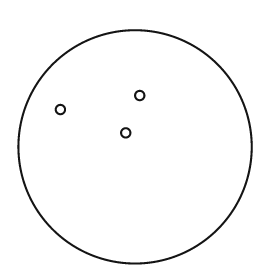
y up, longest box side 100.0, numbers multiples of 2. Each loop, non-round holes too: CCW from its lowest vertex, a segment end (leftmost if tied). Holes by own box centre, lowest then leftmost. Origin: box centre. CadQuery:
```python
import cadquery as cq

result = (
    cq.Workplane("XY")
    .moveTo(0.0, 0.0)
    .circle(50.0)
    .moveTo(-4.0, 6.0)
    .circle(2.0)
    .moveTo(-32.0, 16.0)
    .circle(2.0)
    .moveTo(2.0, 22.0)
    .circle(2.0)
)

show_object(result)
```